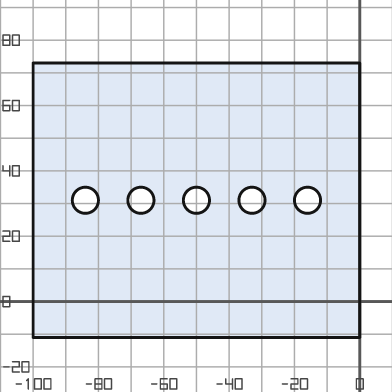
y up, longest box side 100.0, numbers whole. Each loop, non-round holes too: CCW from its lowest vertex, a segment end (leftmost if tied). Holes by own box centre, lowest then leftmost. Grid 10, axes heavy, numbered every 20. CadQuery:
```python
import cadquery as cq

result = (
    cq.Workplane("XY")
    .moveTo(-100.0, -11.0)
    .lineTo(0.0, -11.0)
    .lineTo(0.0, 73.0)
    .lineTo(-100.0, 73.0)
    .close()
    .moveTo(-84.0, 31.0)
    .circle(4.0)
    .moveTo(-67.0, 31.0)
    .circle(4.0)
    .moveTo(-50.0, 31.0)
    .circle(4.0)
    .moveTo(-33.0, 31.0)
    .circle(4.0)
    .moveTo(-16.0, 31.0)
    .circle(4.0)
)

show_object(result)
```